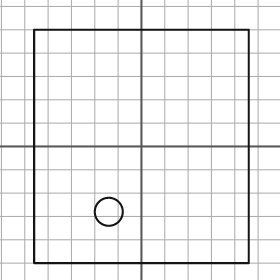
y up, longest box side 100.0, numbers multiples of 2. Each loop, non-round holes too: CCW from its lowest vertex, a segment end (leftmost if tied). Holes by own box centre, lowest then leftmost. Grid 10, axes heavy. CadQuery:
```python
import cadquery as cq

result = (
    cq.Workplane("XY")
    .moveTo(-46.0, -50.0)
    .lineTo(46.0, -50.0)
    .lineTo(46.0, 50.0)
    .lineTo(-46.0, 50.0)
    .close()
    .moveTo(-14.0, -28.0)
    .circle(6.0)
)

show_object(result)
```